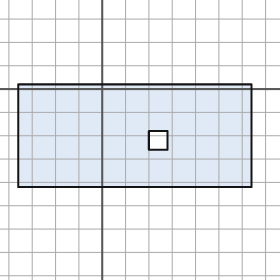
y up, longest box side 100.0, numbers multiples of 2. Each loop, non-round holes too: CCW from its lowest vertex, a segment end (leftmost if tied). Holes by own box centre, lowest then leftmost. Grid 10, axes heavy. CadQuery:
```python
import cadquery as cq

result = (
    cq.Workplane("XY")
    .moveTo(-36.0, -42.0)
    .lineTo(64.0, -42.0)
    .lineTo(64.0, 2.0)
    .lineTo(-36.0, 2.0)
    .close()
    .moveTo(20.0, -26.0)
    .lineTo(28.0, -26.0)
    .lineTo(28.0, -18.0)
    .lineTo(20.0, -18.0)
    .close()
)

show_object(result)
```